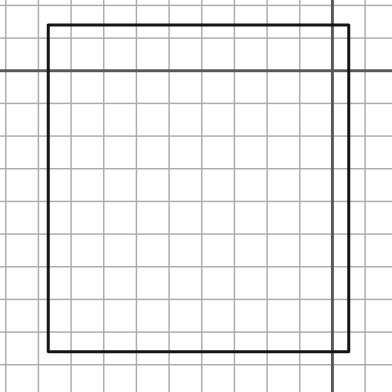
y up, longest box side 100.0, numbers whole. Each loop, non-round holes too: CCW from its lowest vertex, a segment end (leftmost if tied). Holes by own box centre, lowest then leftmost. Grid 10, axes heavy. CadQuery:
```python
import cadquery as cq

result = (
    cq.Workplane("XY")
    .moveTo(-87.0, -86.0)
    .lineTo(5.0, -86.0)
    .lineTo(5.0, 14.0)
    .lineTo(-87.0, 14.0)
    .close()
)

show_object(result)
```